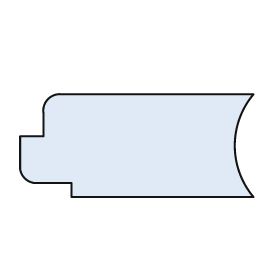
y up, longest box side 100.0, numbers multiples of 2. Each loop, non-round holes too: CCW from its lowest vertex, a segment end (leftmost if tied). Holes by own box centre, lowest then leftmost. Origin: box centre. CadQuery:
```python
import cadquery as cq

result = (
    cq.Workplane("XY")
    .moveTo(-28.0, -22.0)
    .lineTo(50.0, -22.0)
    .threePointArc((42.0, 0.0), (50.0, 22.0))
    .lineTo(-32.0, 22.0)
    .threePointArc((-38.0, 20.0), (-40.0, 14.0))
    .lineTo(-40.0, 4.0)
    .lineTo(-50.0, 4.0)
    .lineTo(-50.0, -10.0)
    .threePointArc((-48.0, -14.0), (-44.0, -16.0))
    .lineTo(-28.0, -16.0)
    .close()
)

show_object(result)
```